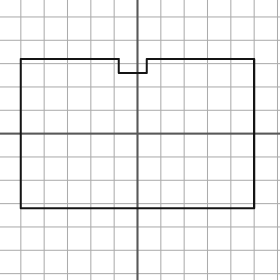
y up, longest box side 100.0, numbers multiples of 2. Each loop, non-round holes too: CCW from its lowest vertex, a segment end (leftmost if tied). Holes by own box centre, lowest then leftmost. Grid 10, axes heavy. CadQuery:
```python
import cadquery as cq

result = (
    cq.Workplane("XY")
    .moveTo(-50.0, -32.0)
    .lineTo(50.0, -32.0)
    .lineTo(50.0, 32.0)
    .lineTo(4.0, 32.0)
    .lineTo(4.0, 26.0)
    .lineTo(-8.0, 26.0)
    .lineTo(-8.0, 32.0)
    .lineTo(-50.0, 32.0)
    .close()
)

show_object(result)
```